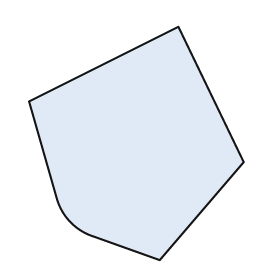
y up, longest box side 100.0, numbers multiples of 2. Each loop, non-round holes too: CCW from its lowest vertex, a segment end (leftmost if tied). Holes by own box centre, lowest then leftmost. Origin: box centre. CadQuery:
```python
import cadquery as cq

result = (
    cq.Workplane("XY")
    .moveTo(10.0, -50.0)
    .lineTo(46.0, -8.0)
    .lineTo(18.0, 50.0)
    .lineTo(-46.0, 18.0)
    .lineTo(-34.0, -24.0)
    .threePointArc((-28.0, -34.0), (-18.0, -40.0))
    .close()
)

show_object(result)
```